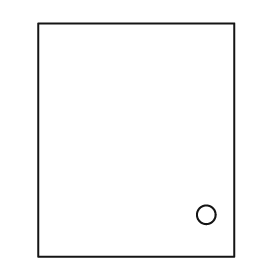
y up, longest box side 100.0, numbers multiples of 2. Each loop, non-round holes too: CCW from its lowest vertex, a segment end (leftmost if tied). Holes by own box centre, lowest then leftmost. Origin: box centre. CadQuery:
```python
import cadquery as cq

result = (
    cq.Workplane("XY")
    .moveTo(-42.0, -50.0)
    .lineTo(42.0, -50.0)
    .lineTo(42.0, 50.0)
    .lineTo(-42.0, 50.0)
    .close()
    .moveTo(30.0, -32.0)
    .circle(4.0)
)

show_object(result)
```